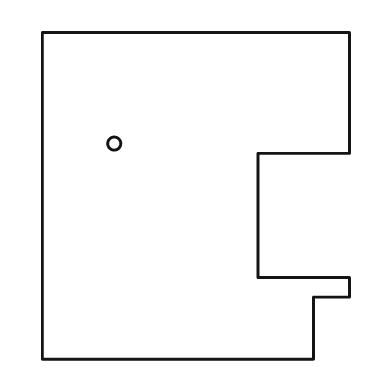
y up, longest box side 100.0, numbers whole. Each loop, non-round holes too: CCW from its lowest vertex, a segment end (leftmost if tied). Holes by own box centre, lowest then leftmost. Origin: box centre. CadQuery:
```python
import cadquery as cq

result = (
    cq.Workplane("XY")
    .moveTo(-47.0, -50.0)
    .lineTo(36.0, -50.0)
    .lineTo(36.0, -31.0)
    .lineTo(47.0, -31.0)
    .lineTo(47.0, -25.0)
    .lineTo(19.0, -25.0)
    .lineTo(19.0, 13.0)
    .lineTo(47.0, 13.0)
    .lineTo(47.0, 50.0)
    .lineTo(-47.0, 50.0)
    .close()
    .moveTo(-25.0, 16.0)
    .circle(2.0)
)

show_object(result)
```